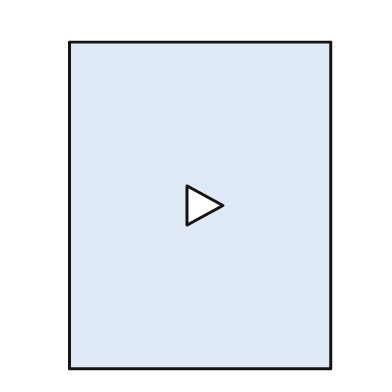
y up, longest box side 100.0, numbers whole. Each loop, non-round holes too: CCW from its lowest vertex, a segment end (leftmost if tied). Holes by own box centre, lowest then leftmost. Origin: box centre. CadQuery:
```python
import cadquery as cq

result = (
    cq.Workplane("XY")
    .moveTo(-40.0, -50.0)
    .lineTo(40.0, -50.0)
    .lineTo(40.0, 50.0)
    .lineTo(-40.0, 50.0)
    .close()
    .moveTo(-4.0, -6.0)
    .lineTo(7.0, 0.0)
    .lineTo(-4.0, 6.0)
    .close()
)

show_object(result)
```